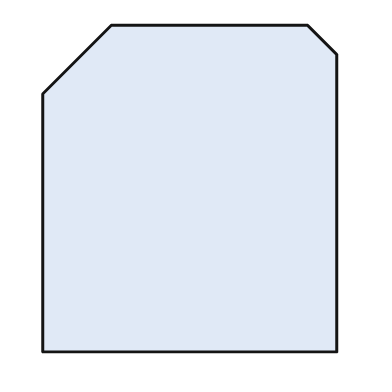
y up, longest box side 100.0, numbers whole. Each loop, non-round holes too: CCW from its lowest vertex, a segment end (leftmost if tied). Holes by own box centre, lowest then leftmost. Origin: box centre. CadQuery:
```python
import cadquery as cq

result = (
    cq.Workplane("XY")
    .moveTo(-45.0, -50.0)
    .lineTo(45.0, -50.0)
    .lineTo(45.0, 41.0)
    .lineTo(36.0, 50.0)
    .lineTo(-24.0, 50.0)
    .lineTo(-45.0, 29.0)
    .close()
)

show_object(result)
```